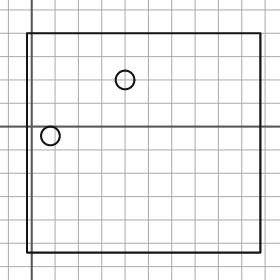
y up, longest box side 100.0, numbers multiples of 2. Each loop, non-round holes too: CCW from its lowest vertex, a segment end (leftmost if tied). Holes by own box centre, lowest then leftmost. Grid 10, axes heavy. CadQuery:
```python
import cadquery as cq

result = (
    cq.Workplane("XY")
    .moveTo(-2.0, -54.0)
    .lineTo(98.0, -54.0)
    .lineTo(98.0, 40.0)
    .lineTo(-2.0, 40.0)
    .close()
    .moveTo(8.0, -4.0)
    .circle(4.0)
    .moveTo(40.0, 20.0)
    .circle(4.0)
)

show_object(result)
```